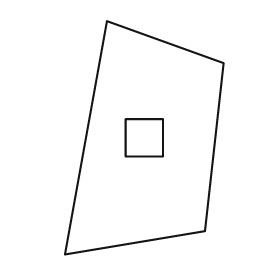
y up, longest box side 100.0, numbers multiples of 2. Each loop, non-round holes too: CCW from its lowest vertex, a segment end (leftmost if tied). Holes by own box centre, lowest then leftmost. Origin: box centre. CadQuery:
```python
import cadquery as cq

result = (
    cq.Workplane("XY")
    .moveTo(-34.0, -50.0)
    .lineTo(26.0, -40.0)
    .lineTo(34.0, 32.0)
    .lineTo(-16.0, 50.0)
    .close()
    .moveTo(-8.0, -8.0)
    .lineTo(8.0, -8.0)
    .lineTo(8.0, 8.0)
    .lineTo(-8.0, 8.0)
    .close()
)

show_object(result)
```